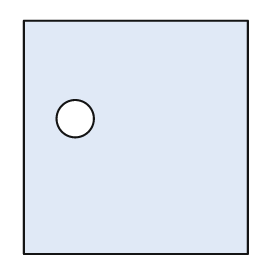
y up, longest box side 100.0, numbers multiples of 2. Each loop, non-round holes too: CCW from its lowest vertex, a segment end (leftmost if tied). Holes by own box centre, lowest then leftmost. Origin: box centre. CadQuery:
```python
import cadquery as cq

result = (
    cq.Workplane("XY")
    .moveTo(-48.0, -50.0)
    .lineTo(48.0, -50.0)
    .lineTo(48.0, 50.0)
    .lineTo(-48.0, 50.0)
    .close()
    .moveTo(-26.0, 8.0)
    .circle(8.0)
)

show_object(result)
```